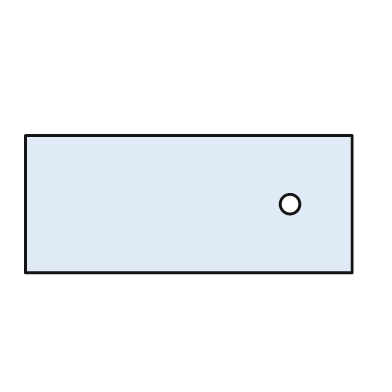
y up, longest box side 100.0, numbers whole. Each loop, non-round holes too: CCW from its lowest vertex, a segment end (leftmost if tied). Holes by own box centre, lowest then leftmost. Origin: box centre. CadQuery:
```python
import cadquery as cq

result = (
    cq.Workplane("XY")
    .moveTo(-50.0, -21.0)
    .lineTo(50.0, -21.0)
    .lineTo(50.0, 21.0)
    .lineTo(-50.0, 21.0)
    .close()
    .moveTo(31.0, 0.0)
    .circle(3.0)
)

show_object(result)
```